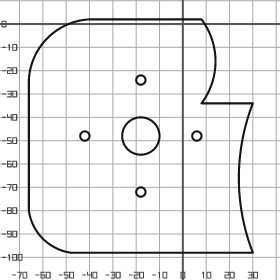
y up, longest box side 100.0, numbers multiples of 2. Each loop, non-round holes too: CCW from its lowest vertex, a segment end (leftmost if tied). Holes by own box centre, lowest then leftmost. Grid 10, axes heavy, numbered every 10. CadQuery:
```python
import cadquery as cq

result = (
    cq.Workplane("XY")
    .moveTo(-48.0, -98.0)
    .lineTo(30.0, -98.0)
    .threePointArc((24.0, -66.0), (30.0, -34.0))
    .lineTo(8.0, -34.0)
    .threePointArc((14.0, -16.0), (8.0, 2.0))
    .lineTo(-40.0, 2.0)
    .threePointArc((-58.0, -6.0), (-66.0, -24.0))
    .lineTo(-66.0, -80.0)
    .threePointArc((-60.0, -92.0), (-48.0, -98.0))
    .close()
    .moveTo(-18.0, -72.0)
    .circle(2.0)
    .moveTo(-42.0, -48.0)
    .circle(2.0)
    .moveTo(-18.0, -48.0)
    .circle(8.0)
    .moveTo(6.0, -48.0)
    .circle(2.0)
    .moveTo(-18.0, -24.0)
    .circle(2.0)
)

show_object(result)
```